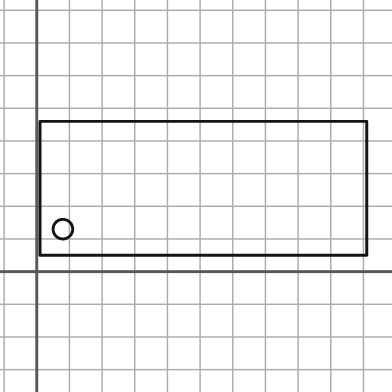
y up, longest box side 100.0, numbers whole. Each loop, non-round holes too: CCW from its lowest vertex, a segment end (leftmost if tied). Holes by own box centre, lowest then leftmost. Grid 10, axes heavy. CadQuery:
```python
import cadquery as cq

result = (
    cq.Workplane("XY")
    .moveTo(1.0, 5.0)
    .lineTo(101.0, 5.0)
    .lineTo(101.0, 46.0)
    .lineTo(1.0, 46.0)
    .close()
    .moveTo(8.0, 13.0)
    .circle(3.0)
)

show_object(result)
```